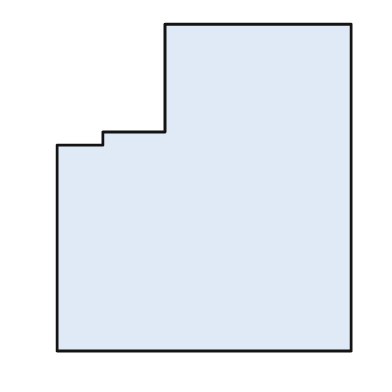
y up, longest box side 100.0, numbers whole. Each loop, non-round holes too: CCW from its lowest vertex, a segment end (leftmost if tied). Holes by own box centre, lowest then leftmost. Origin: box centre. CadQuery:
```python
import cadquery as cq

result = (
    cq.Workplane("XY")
    .moveTo(-45.0, -50.0)
    .lineTo(45.0, -50.0)
    .lineTo(45.0, 50.0)
    .lineTo(-12.0, 50.0)
    .lineTo(-12.0, 17.0)
    .lineTo(-31.0, 17.0)
    .lineTo(-31.0, 13.0)
    .lineTo(-45.0, 13.0)
    .close()
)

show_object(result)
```